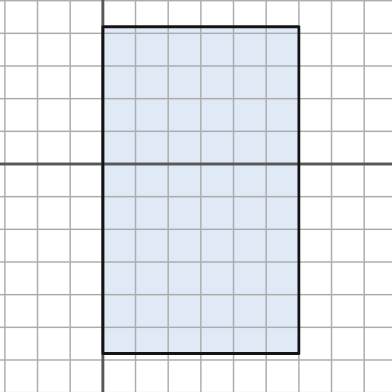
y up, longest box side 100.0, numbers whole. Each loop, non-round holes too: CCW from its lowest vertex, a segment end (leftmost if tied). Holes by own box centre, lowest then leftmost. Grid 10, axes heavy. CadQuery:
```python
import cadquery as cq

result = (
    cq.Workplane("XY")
    .moveTo(0.0, -58.0)
    .lineTo(60.0, -58.0)
    .lineTo(60.0, 42.0)
    .lineTo(0.0, 42.0)
    .close()
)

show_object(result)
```